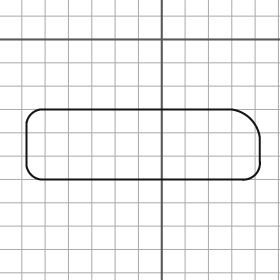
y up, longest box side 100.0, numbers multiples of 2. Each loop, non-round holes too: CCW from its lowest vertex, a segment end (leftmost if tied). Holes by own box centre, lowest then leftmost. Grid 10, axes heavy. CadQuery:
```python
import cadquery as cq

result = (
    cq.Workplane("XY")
    .moveTo(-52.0, -60.0)
    .lineTo(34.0, -60.0)
    .threePointArc((40.0, -58.0), (42.0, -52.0))
    .lineTo(42.0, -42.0)
    .threePointArc((38.0, -34.0), (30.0, -30.0))
    .lineTo(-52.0, -30.0)
    .threePointArc((-56.0, -32.0), (-58.0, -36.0))
    .lineTo(-58.0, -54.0)
    .threePointArc((-56.0, -58.0), (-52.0, -60.0))
    .close()
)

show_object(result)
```